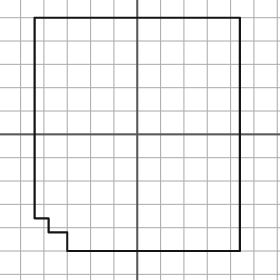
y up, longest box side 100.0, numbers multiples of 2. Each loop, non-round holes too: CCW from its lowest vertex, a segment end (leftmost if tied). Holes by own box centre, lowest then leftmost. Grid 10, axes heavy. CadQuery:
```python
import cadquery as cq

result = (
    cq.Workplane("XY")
    .moveTo(-30.0, -50.0)
    .lineTo(44.0, -50.0)
    .lineTo(44.0, 50.0)
    .lineTo(-44.0, 50.0)
    .lineTo(-44.0, -36.0)
    .lineTo(-38.0, -36.0)
    .lineTo(-38.0, -42.0)
    .lineTo(-30.0, -42.0)
    .close()
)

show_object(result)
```